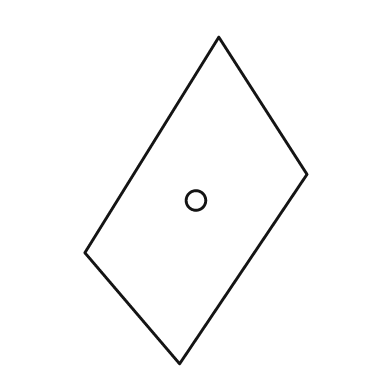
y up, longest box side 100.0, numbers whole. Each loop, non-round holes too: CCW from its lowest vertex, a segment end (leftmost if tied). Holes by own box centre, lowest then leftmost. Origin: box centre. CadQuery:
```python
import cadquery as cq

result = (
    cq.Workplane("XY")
    .moveTo(-5.0, -50.0)
    .lineTo(34.0, 8.0)
    .lineTo(7.0, 50.0)
    .lineTo(-34.0, -16.0)
    .close()
    .moveTo(0.0, 0.0)
    .circle(3.0)
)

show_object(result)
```